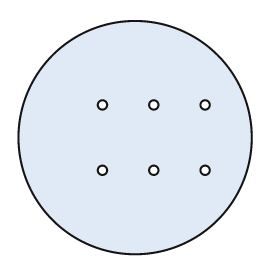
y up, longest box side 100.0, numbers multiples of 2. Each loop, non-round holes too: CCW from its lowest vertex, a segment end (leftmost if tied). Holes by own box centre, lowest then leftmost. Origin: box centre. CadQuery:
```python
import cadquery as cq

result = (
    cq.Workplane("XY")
    .moveTo(0.0, 0.0)
    .circle(50.0)
    .moveTo(-14.0, -14.0)
    .circle(2.0)
    .moveTo(8.0, -14.0)
    .circle(2.0)
    .moveTo(30.0, -14.0)
    .circle(2.0)
    .moveTo(-14.0, 14.0)
    .circle(2.0)
    .moveTo(8.0, 14.0)
    .circle(2.0)
    .moveTo(30.0, 14.0)
    .circle(2.0)
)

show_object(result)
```